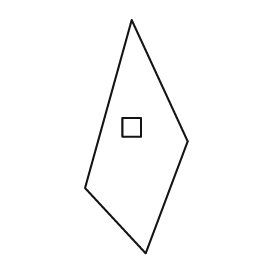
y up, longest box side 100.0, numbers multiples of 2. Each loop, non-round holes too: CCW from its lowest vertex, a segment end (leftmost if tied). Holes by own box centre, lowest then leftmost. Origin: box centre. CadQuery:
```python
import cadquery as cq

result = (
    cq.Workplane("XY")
    .moveTo(4.0, -50.0)
    .lineTo(22.0, -2.0)
    .lineTo(-2.0, 50.0)
    .lineTo(-22.0, -22.0)
    .close()
    .moveTo(-6.0, 0.0)
    .lineTo(2.0, 0.0)
    .lineTo(2.0, 8.0)
    .lineTo(-6.0, 8.0)
    .close()
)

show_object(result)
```